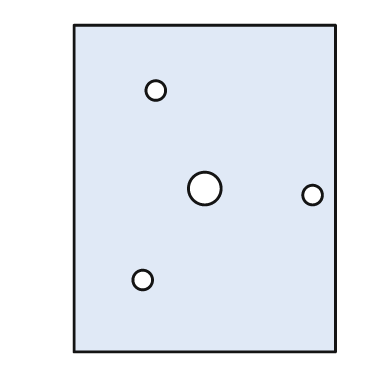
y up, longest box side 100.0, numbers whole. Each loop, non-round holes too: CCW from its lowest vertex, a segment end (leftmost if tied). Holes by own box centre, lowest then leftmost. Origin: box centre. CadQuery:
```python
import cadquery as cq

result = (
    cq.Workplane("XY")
    .moveTo(-40.0, -50.0)
    .lineTo(40.0, -50.0)
    .lineTo(40.0, 50.0)
    .lineTo(-40.0, 50.0)
    .close()
    .moveTo(-19.0, -28.0)
    .circle(3.0)
    .moveTo(33.0, -2.0)
    .circle(3.0)
    .moveTo(0.0, 0.0)
    .circle(5.0)
    .moveTo(-15.0, 30.0)
    .circle(3.0)
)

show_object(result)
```